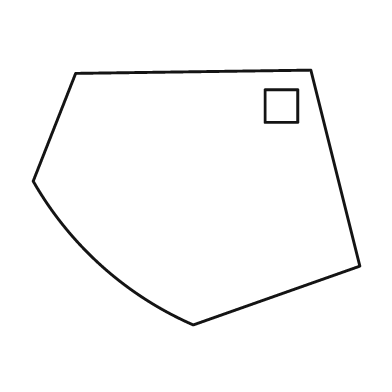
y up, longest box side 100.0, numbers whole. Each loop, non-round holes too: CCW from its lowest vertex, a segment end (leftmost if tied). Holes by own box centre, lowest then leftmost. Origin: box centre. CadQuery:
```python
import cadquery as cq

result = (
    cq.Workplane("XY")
    .moveTo(-1.0, -39.0)
    .lineTo(50.0, -21.0)
    .lineTo(35.0, 39.0)
    .lineTo(-37.0, 38.0)
    .lineTo(-50.0, 5.0)
    .threePointArc((-29.0, -21.0), (-1.0, -39.0))
    .close()
    .moveTo(21.0, 23.0)
    .lineTo(31.0, 23.0)
    .lineTo(31.0, 33.0)
    .lineTo(21.0, 33.0)
    .close()
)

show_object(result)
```